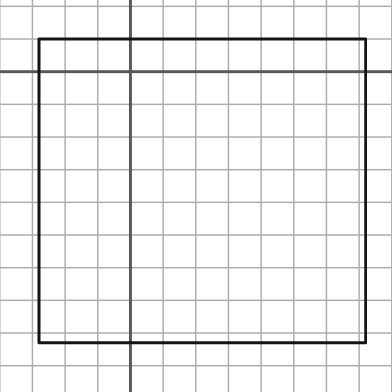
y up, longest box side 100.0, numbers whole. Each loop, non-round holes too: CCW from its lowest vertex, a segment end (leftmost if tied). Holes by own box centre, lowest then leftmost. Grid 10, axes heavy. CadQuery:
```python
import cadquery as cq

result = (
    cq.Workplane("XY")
    .moveTo(-28.0, -83.0)
    .lineTo(72.0, -83.0)
    .lineTo(72.0, 10.0)
    .lineTo(-28.0, 10.0)
    .close()
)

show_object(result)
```